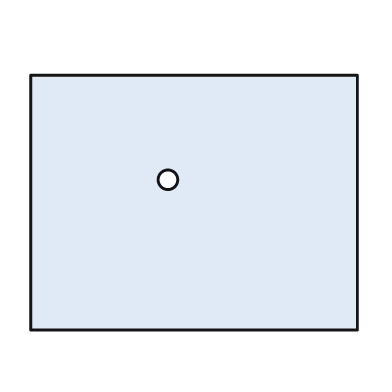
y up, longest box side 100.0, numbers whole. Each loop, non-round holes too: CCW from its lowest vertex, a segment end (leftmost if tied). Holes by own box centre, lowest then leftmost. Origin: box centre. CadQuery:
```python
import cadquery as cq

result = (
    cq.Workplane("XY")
    .moveTo(-50.0, -39.0)
    .lineTo(50.0, -39.0)
    .lineTo(50.0, 39.0)
    .lineTo(-50.0, 39.0)
    .close()
    .moveTo(-8.0, 7.0)
    .circle(3.0)
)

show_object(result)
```